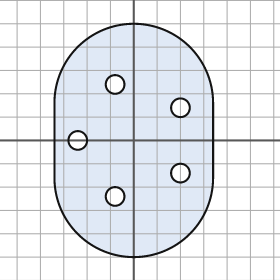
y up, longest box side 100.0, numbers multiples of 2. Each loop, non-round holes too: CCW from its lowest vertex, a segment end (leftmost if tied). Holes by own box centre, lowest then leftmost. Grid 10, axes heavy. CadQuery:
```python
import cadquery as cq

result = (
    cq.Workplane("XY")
    .moveTo(-34.0, -16.0)
    .threePointArc((0.0, -50.0), (34.0, -16.0))
    .lineTo(34.0, 16.0)
    .threePointArc((0.0, 50.0), (-34.0, 16.0))
    .close()
    .moveTo(-8.0, -24.0)
    .circle(4.0)
    .moveTo(20.0, -14.0)
    .circle(4.0)
    .moveTo(-24.0, 0.0)
    .circle(4.0)
    .moveTo(20.0, 14.0)
    .circle(4.0)
    .moveTo(-8.0, 24.0)
    .circle(4.0)
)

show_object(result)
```